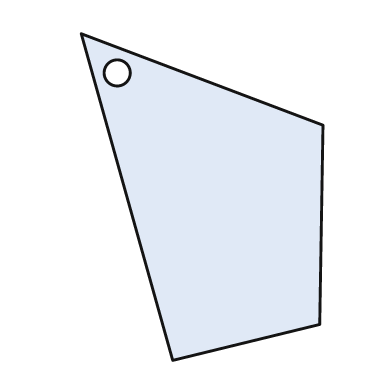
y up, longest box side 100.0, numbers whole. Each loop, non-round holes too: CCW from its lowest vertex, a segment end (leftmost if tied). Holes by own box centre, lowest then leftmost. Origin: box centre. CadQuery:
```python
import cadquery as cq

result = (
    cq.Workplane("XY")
    .moveTo(-9.0, -50.0)
    .lineTo(36.0, -39.0)
    .lineTo(37.0, 22.0)
    .lineTo(-37.0, 50.0)
    .close()
    .moveTo(-26.0, 38.0)
    .circle(4.0)
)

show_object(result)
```